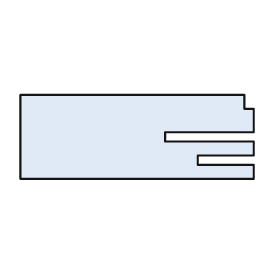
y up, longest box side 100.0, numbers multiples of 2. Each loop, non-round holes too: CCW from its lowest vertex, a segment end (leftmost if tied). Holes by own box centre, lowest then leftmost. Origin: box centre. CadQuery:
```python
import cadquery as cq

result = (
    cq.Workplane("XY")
    .moveTo(-50.0, -18.0)
    .lineTo(50.0, -18.0)
    .lineTo(50.0, -12.0)
    .lineTo(26.0, -12.0)
    .lineTo(26.0, -8.0)
    .lineTo(50.0, -8.0)
    .lineTo(50.0, -2.0)
    .lineTo(12.0, -2.0)
    .lineTo(12.0, 2.0)
    .lineTo(50.0, 2.0)
    .lineTo(50.0, 12.0)
    .lineTo(46.0, 12.0)
    .lineTo(46.0, 18.0)
    .lineTo(-50.0, 18.0)
    .close()
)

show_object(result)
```